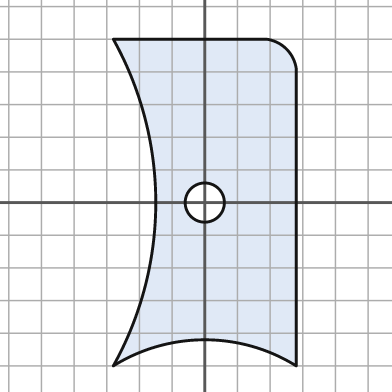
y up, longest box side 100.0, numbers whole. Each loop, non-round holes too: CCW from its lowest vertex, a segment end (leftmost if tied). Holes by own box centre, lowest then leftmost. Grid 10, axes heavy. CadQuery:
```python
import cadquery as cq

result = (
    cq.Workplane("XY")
    .moveTo(-28.0, -50.0)
    .threePointArc((0.0, -42.0), (28.0, -50.0))
    .lineTo(28.0, 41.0)
    .threePointArc((25.0, 47.0), (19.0, 50.0))
    .lineTo(-28.0, 50.0)
    .threePointArc((-15.0, 0.0), (-28.0, -50.0))
    .close()
    .moveTo(0.0, 0.0)
    .circle(6.0)
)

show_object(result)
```